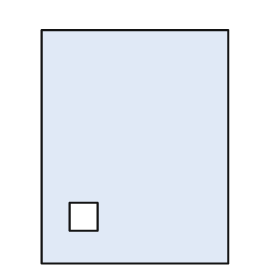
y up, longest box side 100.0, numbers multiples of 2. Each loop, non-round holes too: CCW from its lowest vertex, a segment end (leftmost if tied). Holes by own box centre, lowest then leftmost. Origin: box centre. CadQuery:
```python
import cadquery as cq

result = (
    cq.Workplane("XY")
    .moveTo(-40.0, -50.0)
    .lineTo(40.0, -50.0)
    .lineTo(40.0, 50.0)
    .lineTo(-40.0, 50.0)
    .close()
    .moveTo(-28.0, -36.0)
    .lineTo(-16.0, -36.0)
    .lineTo(-16.0, -24.0)
    .lineTo(-28.0, -24.0)
    .close()
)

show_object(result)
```